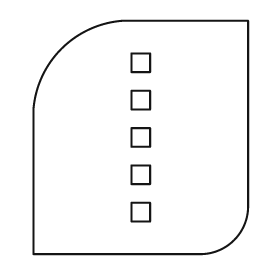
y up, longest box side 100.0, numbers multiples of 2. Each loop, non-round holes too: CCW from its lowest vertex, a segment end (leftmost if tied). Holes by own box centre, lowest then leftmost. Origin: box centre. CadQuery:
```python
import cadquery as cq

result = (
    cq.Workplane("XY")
    .moveTo(-46.0, -50.0)
    .lineTo(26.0, -50.0)
    .threePointArc((40.0, -44.0), (46.0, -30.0))
    .lineTo(46.0, 50.0)
    .lineTo(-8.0, 50.0)
    .threePointArc((-34.0, 38.0), (-46.0, 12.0))
    .close()
    .moveTo(-4.0, -36.0)
    .lineTo(4.0, -36.0)
    .lineTo(4.0, -28.0)
    .lineTo(-4.0, -28.0)
    .close()
    .moveTo(-4.0, -20.0)
    .lineTo(4.0, -20.0)
    .lineTo(4.0, -12.0)
    .lineTo(-4.0, -12.0)
    .close()
    .moveTo(-4.0, -4.0)
    .lineTo(4.0, -4.0)
    .lineTo(4.0, 4.0)
    .lineTo(-4.0, 4.0)
    .close()
    .moveTo(-4.0, 12.0)
    .lineTo(4.0, 12.0)
    .lineTo(4.0, 20.0)
    .lineTo(-4.0, 20.0)
    .close()
    .moveTo(-4.0, 28.0)
    .lineTo(4.0, 28.0)
    .lineTo(4.0, 36.0)
    .lineTo(-4.0, 36.0)
    .close()
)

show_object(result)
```